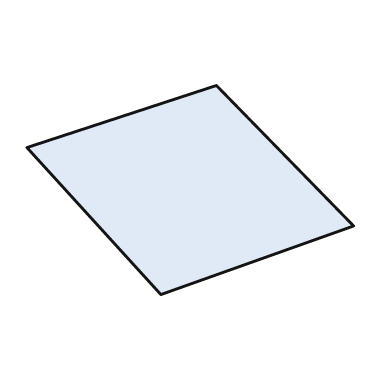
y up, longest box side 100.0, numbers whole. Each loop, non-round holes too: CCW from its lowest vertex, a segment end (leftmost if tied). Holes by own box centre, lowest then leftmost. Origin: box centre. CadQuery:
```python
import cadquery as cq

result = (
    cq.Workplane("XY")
    .moveTo(-9.0, -32.0)
    .lineTo(50.0, -11.0)
    .lineTo(8.0, 32.0)
    .lineTo(-50.0, 13.0)
    .close()
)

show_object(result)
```